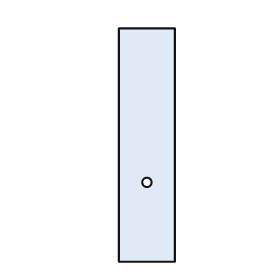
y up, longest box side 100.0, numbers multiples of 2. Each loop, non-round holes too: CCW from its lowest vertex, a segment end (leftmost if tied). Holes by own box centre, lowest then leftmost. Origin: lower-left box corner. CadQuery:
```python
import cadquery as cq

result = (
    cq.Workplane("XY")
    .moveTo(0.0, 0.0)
    .lineTo(24.0, 0.0)
    .lineTo(24.0, 100.0)
    .lineTo(0.0, 100.0)
    .close()
    .moveTo(12.0, 34.0)
    .circle(2.0)
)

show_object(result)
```